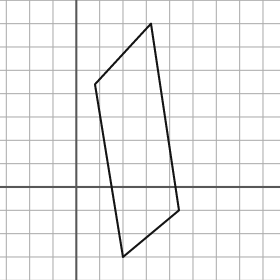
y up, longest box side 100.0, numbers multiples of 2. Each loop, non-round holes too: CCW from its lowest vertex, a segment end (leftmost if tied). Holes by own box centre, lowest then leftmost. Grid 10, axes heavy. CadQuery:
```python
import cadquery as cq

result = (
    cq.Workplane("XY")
    .moveTo(20.0, -30.0)
    .lineTo(44.0, -10.0)
    .lineTo(32.0, 70.0)
    .lineTo(8.0, 44.0)
    .close()
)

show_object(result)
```